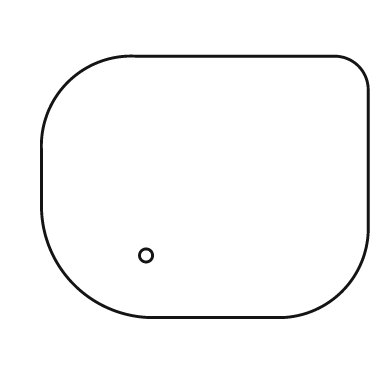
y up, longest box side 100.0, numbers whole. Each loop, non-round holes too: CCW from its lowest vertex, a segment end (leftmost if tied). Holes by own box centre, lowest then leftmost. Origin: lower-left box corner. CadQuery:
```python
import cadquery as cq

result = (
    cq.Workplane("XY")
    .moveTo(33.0, 0.0)
    .lineTo(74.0, 0.0)
    .threePointArc((92.0, 8.0), (100.0, 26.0))
    .lineTo(100.0, 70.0)
    .threePointArc((97.0, 77.0), (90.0, 80.0))
    .lineTo(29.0, 80.0)
    .threePointArc((8.0, 72.0), (0.0, 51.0))
    .lineTo(0.0, 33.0)
    .threePointArc((10.0, 10.0), (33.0, 0.0))
    .close()
    .moveTo(32.0, 19.0)
    .circle(2.0)
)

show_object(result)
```